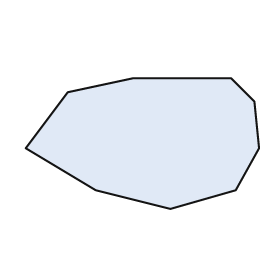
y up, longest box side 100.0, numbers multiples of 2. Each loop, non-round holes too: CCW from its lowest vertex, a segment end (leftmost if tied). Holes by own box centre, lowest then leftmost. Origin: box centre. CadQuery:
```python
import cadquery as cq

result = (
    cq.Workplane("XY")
    .moveTo(12.0, -28.0)
    .lineTo(40.0, -20.0)
    .lineTo(50.0, -2.0)
    .lineTo(48.0, 18.0)
    .lineTo(38.0, 28.0)
    .lineTo(-4.0, 28.0)
    .lineTo(-32.0, 22.0)
    .lineTo(-50.0, -2.0)
    .lineTo(-20.0, -20.0)
    .close()
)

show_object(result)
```